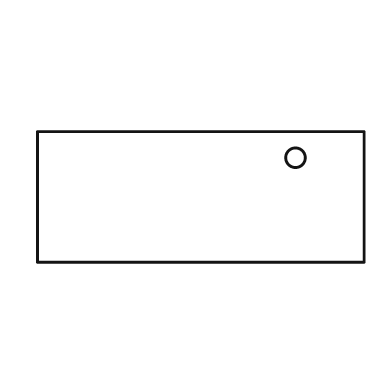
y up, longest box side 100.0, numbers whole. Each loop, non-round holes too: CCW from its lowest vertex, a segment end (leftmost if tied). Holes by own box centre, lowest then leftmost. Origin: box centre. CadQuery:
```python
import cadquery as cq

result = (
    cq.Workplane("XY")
    .moveTo(-50.0, -20.0)
    .lineTo(50.0, -20.0)
    .lineTo(50.0, 20.0)
    .lineTo(-50.0, 20.0)
    .close()
    .moveTo(29.0, 12.0)
    .circle(3.0)
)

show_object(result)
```